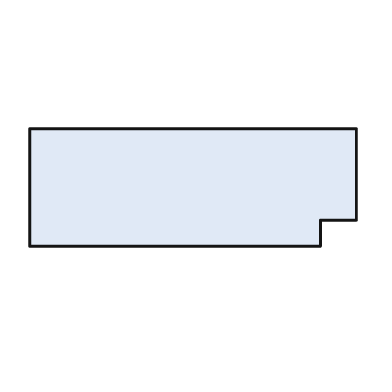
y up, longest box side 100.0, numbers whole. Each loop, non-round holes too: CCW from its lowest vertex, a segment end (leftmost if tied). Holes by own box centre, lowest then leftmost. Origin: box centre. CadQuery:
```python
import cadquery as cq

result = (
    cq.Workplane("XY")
    .moveTo(-50.0, -18.0)
    .lineTo(39.0, -18.0)
    .lineTo(39.0, -10.0)
    .lineTo(50.0, -10.0)
    .lineTo(50.0, 18.0)
    .lineTo(-50.0, 18.0)
    .close()
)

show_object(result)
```